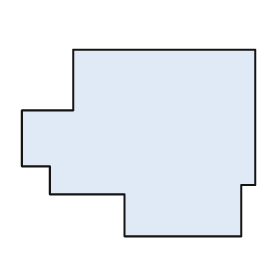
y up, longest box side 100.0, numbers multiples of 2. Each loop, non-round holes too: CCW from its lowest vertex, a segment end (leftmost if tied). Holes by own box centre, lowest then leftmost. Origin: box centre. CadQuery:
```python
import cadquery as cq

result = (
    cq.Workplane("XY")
    .moveTo(-6.0, -40.0)
    .lineTo(44.0, -40.0)
    .lineTo(44.0, -18.0)
    .lineTo(50.0, -18.0)
    .lineTo(50.0, 40.0)
    .lineTo(-28.0, 40.0)
    .lineTo(-28.0, 14.0)
    .lineTo(-50.0, 14.0)
    .lineTo(-50.0, -10.0)
    .lineTo(-38.0, -10.0)
    .lineTo(-38.0, -22.0)
    .lineTo(-6.0, -22.0)
    .close()
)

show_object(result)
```